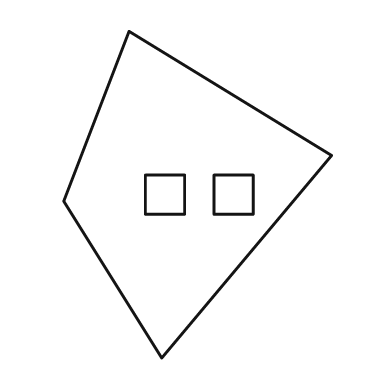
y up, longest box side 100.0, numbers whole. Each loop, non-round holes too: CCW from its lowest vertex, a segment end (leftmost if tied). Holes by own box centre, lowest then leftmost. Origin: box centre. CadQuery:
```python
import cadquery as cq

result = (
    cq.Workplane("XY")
    .moveTo(-11.0, -50.0)
    .lineTo(41.0, 12.0)
    .lineTo(-21.0, 50.0)
    .lineTo(-41.0, -2.0)
    .close()
    .moveTo(-16.0, -6.0)
    .lineTo(-4.0, -6.0)
    .lineTo(-4.0, 6.0)
    .lineTo(-16.0, 6.0)
    .close()
    .moveTo(5.0, -6.0)
    .lineTo(17.0, -6.0)
    .lineTo(17.0, 6.0)
    .lineTo(5.0, 6.0)
    .close()
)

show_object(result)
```